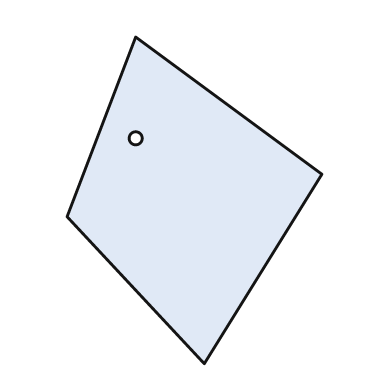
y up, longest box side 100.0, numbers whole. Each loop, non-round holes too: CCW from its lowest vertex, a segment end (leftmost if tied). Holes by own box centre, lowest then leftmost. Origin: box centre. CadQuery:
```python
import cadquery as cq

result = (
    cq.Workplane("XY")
    .moveTo(3.0, -50.0)
    .lineTo(39.0, 8.0)
    .lineTo(-18.0, 50.0)
    .lineTo(-39.0, -5.0)
    .close()
    .moveTo(-18.0, 19.0)
    .circle(2.0)
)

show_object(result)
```